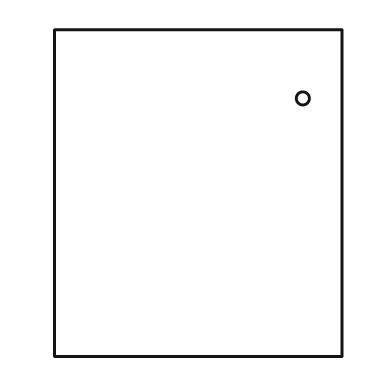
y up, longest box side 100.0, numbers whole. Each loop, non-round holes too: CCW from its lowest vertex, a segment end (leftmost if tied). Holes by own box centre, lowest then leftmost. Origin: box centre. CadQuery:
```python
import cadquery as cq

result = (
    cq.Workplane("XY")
    .moveTo(-44.0, -50.0)
    .lineTo(44.0, -50.0)
    .lineTo(44.0, 50.0)
    .lineTo(-44.0, 50.0)
    .close()
    .moveTo(32.0, 29.0)
    .circle(2.0)
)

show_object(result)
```